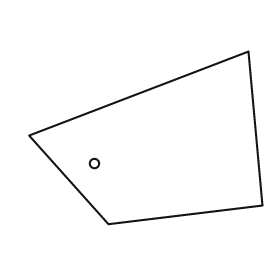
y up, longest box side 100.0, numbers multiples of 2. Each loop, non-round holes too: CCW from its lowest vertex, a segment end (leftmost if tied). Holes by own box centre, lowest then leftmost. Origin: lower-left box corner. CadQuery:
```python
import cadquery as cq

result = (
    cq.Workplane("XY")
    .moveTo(34.0, 0.0)
    .lineTo(100.0, 8.0)
    .lineTo(94.0, 74.0)
    .lineTo(0.0, 38.0)
    .close()
    .moveTo(28.0, 26.0)
    .circle(2.0)
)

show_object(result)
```